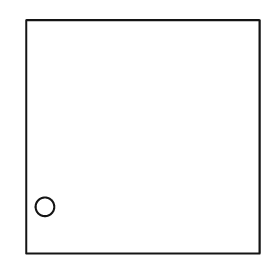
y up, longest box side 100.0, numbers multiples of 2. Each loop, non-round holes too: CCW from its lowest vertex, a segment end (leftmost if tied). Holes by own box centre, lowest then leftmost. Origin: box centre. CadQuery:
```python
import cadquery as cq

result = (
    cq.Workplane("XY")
    .moveTo(-50.0, -50.0)
    .lineTo(50.0, -50.0)
    .lineTo(50.0, 50.0)
    .lineTo(-50.0, 50.0)
    .close()
    .moveTo(-42.0, -30.0)
    .circle(4.0)
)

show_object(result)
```